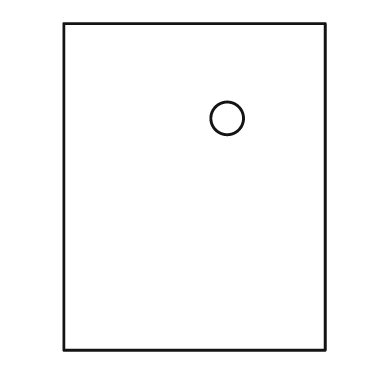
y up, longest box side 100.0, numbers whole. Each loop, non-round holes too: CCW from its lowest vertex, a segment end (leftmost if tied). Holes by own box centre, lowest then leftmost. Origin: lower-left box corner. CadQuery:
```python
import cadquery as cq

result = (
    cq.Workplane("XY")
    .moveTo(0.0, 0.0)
    .lineTo(80.0, 0.0)
    .lineTo(80.0, 100.0)
    .lineTo(0.0, 100.0)
    .close()
    .moveTo(50.0, 71.0)
    .circle(5.0)
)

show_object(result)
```